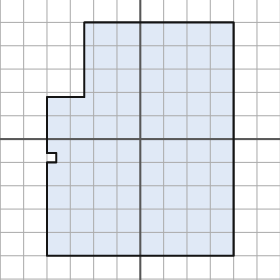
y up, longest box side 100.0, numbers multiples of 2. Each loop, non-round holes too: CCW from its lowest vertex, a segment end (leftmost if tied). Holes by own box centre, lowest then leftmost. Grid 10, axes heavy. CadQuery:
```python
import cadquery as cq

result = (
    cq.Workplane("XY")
    .moveTo(-40.0, -50.0)
    .lineTo(40.0, -50.0)
    .lineTo(40.0, 50.0)
    .lineTo(-24.0, 50.0)
    .lineTo(-24.0, 18.0)
    .lineTo(-40.0, 18.0)
    .lineTo(-40.0, -6.0)
    .lineTo(-36.0, -6.0)
    .lineTo(-36.0, -10.0)
    .lineTo(-40.0, -10.0)
    .close()
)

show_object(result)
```